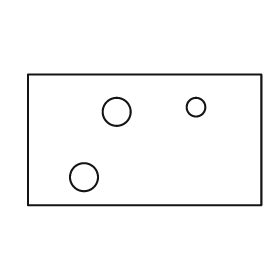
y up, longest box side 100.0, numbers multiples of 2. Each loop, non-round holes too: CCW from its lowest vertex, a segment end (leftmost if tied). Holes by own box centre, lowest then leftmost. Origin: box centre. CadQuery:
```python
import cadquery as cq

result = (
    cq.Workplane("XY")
    .moveTo(-50.0, -28.0)
    .lineTo(50.0, -28.0)
    .lineTo(50.0, 28.0)
    .lineTo(-50.0, 28.0)
    .close()
    .moveTo(-26.0, -16.0)
    .circle(6.0)
    .moveTo(-12.0, 12.0)
    .circle(6.0)
    .moveTo(22.0, 14.0)
    .circle(4.0)
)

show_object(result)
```